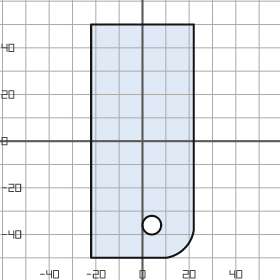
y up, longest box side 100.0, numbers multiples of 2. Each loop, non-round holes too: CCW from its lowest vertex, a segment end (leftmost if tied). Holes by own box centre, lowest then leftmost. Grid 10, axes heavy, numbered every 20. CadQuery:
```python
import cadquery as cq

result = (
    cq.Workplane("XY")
    .moveTo(-22.0, -50.0)
    .lineTo(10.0, -50.0)
    .threePointArc((18.0, -46.0), (22.0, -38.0))
    .lineTo(22.0, 50.0)
    .lineTo(-22.0, 50.0)
    .close()
    .moveTo(4.0, -36.0)
    .circle(4.0)
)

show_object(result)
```